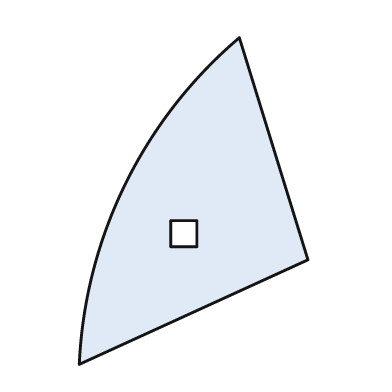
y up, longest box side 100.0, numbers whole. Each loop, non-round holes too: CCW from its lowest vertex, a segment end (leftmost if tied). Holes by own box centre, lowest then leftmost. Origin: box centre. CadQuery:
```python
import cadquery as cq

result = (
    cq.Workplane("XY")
    .moveTo(-35.0, -50.0)
    .lineTo(35.0, -18.0)
    .lineTo(14.0, 50.0)
    .threePointArc((-21.0, 5.0), (-35.0, -50.0))
    .close()
    .moveTo(-7.0, -14.0)
    .lineTo(1.0, -14.0)
    .lineTo(1.0, -6.0)
    .lineTo(-7.0, -6.0)
    .close()
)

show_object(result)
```